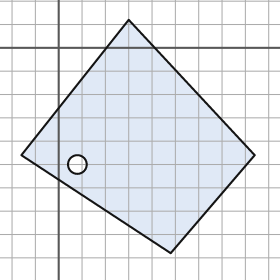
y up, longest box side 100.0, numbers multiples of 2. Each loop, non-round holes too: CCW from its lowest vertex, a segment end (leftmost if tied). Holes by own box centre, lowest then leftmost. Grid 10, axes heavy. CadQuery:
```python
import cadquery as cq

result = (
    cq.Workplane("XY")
    .moveTo(48.0, -88.0)
    .lineTo(84.0, -46.0)
    .lineTo(30.0, 12.0)
    .lineTo(-16.0, -46.0)
    .close()
    .moveTo(8.0, -50.0)
    .circle(4.0)
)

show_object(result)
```